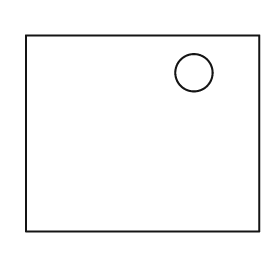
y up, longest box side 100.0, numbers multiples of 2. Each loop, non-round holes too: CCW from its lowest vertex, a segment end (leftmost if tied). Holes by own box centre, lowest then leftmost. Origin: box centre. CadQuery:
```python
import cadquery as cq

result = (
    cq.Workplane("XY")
    .moveTo(-50.0, -42.0)
    .lineTo(50.0, -42.0)
    .lineTo(50.0, 42.0)
    .lineTo(-50.0, 42.0)
    .close()
    .moveTo(22.0, 26.0)
    .circle(8.0)
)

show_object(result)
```